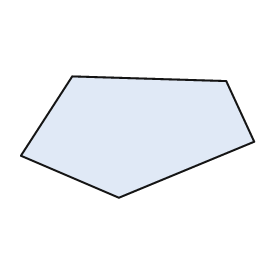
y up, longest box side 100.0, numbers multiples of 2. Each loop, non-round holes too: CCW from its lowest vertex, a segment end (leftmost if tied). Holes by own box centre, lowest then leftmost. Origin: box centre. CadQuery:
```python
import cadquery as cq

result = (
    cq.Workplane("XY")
    .moveTo(-8.0, -26.0)
    .lineTo(50.0, -2.0)
    .lineTo(38.0, 24.0)
    .lineTo(-28.0, 26.0)
    .lineTo(-50.0, -8.0)
    .close()
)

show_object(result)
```